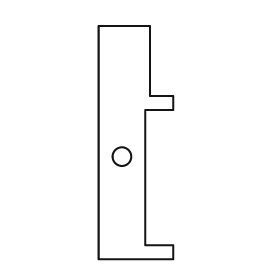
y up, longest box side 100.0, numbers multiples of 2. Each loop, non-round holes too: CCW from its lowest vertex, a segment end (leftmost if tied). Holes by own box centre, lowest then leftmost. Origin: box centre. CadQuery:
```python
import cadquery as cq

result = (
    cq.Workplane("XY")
    .moveTo(-16.0, -50.0)
    .lineTo(16.0, -50.0)
    .lineTo(16.0, -44.0)
    .lineTo(4.0, -44.0)
    .lineTo(4.0, 14.0)
    .lineTo(16.0, 14.0)
    .lineTo(16.0, 20.0)
    .lineTo(6.0, 20.0)
    .lineTo(6.0, 50.0)
    .lineTo(-16.0, 50.0)
    .close()
    .moveTo(-6.0, -6.0)
    .circle(4.0)
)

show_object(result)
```